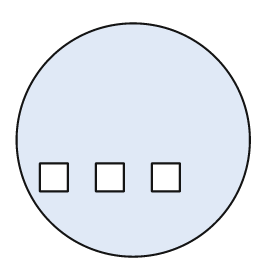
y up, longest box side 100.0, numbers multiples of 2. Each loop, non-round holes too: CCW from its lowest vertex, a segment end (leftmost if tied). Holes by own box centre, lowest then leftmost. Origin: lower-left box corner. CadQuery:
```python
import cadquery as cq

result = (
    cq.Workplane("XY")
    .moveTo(50.0, 50.0)
    .circle(50.0)
    .moveTo(10.0, 28.0)
    .lineTo(22.0, 28.0)
    .lineTo(22.0, 40.0)
    .lineTo(10.0, 40.0)
    .close()
    .moveTo(34.0, 28.0)
    .lineTo(46.0, 28.0)
    .lineTo(46.0, 40.0)
    .lineTo(34.0, 40.0)
    .close()
    .moveTo(58.0, 28.0)
    .lineTo(70.0, 28.0)
    .lineTo(70.0, 40.0)
    .lineTo(58.0, 40.0)
    .close()
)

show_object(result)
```